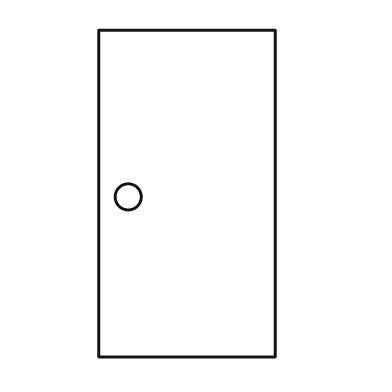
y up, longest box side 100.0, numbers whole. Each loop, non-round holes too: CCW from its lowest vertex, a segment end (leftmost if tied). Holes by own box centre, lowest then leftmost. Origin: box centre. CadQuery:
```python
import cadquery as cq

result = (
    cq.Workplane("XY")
    .moveTo(-27.0, -50.0)
    .lineTo(27.0, -50.0)
    .lineTo(27.0, 50.0)
    .lineTo(-27.0, 50.0)
    .close()
    .moveTo(-18.0, -1.0)
    .circle(4.0)
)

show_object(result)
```